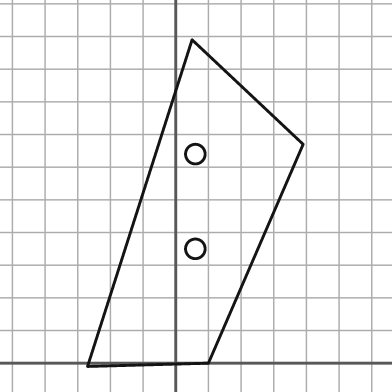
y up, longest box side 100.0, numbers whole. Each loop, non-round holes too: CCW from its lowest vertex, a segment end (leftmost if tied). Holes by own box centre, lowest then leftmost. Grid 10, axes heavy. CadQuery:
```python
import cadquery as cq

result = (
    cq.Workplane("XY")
    .moveTo(-27.0, -1.0)
    .lineTo(10.0, 0.0)
    .lineTo(39.0, 67.0)
    .lineTo(5.0, 99.0)
    .close()
    .moveTo(6.0, 35.0)
    .circle(3.0)
    .moveTo(6.0, 64.0)
    .circle(3.0)
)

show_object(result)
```